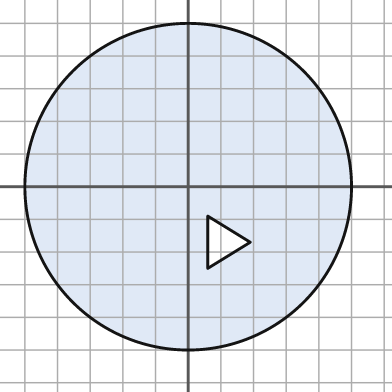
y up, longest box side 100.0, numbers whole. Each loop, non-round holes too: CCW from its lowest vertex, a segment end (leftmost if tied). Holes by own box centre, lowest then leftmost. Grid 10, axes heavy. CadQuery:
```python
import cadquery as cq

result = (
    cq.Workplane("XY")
    .moveTo(0.0, 0.0)
    .circle(50.0)
    .moveTo(6.0, -25.0)
    .lineTo(19.0, -17.0)
    .lineTo(6.0, -9.0)
    .close()
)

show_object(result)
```